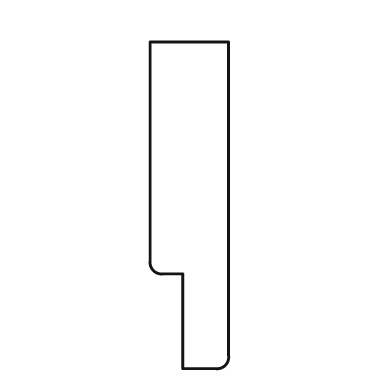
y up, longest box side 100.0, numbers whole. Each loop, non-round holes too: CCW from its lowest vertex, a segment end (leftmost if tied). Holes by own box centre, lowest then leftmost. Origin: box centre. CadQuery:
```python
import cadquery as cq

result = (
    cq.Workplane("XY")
    .moveTo(-2.0, -50.0)
    .lineTo(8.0, -50.0)
    .threePointArc((11.0, -49.0), (12.0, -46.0))
    .lineTo(12.0, 50.0)
    .lineTo(-12.0, 50.0)
    .lineTo(-12.0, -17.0)
    .threePointArc((-11.0, -20.0), (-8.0, -21.0))
    .lineTo(-2.0, -21.0)
    .close()
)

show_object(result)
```